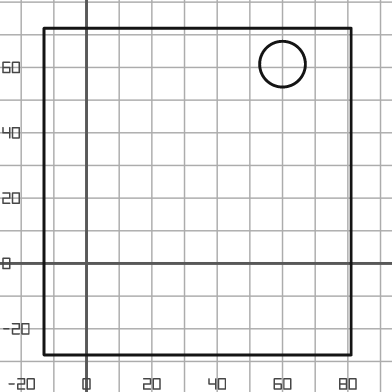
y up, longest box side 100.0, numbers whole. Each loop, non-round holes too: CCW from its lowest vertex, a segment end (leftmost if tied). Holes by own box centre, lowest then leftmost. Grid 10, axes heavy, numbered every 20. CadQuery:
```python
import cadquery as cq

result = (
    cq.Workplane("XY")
    .moveTo(-13.0, -28.0)
    .lineTo(81.0, -28.0)
    .lineTo(81.0, 72.0)
    .lineTo(-13.0, 72.0)
    .close()
    .moveTo(60.0, 61.0)
    .circle(7.0)
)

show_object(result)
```